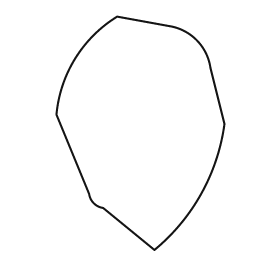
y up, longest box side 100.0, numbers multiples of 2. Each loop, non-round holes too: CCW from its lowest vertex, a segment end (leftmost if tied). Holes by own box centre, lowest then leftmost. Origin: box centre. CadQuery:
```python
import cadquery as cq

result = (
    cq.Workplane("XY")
    .moveTo(6.0, -50.0)
    .threePointArc((26.0, -26.0), (36.0, 4.0))
    .lineTo(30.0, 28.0)
    .threePointArc((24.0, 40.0), (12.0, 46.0))
    .lineTo(-10.0, 50.0)
    .threePointArc((-28.0, 32.0), (-36.0, 8.0))
    .lineTo(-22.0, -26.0)
    .threePointArc((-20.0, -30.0), (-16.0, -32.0))
    .close()
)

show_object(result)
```